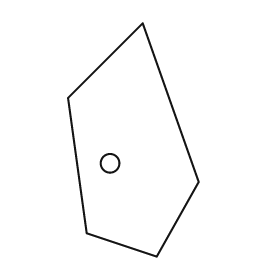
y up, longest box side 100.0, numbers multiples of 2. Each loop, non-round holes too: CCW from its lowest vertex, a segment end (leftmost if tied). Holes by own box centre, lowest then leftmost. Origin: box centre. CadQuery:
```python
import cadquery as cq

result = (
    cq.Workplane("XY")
    .moveTo(10.0, -50.0)
    .lineTo(28.0, -18.0)
    .lineTo(4.0, 50.0)
    .lineTo(-28.0, 18.0)
    .lineTo(-20.0, -40.0)
    .close()
    .moveTo(-10.0, -10.0)
    .circle(4.0)
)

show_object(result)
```